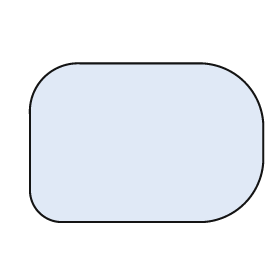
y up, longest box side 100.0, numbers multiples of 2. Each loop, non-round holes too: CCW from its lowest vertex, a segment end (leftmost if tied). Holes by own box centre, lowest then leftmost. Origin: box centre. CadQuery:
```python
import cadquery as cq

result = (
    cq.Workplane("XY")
    .moveTo(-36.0, -34.0)
    .lineTo(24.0, -34.0)
    .threePointArc((42.0, -26.0), (50.0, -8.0))
    .lineTo(50.0, 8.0)
    .threePointArc((42.0, 26.0), (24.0, 34.0))
    .lineTo(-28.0, 34.0)
    .threePointArc((-44.0, 28.0), (-50.0, 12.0))
    .lineTo(-50.0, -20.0)
    .threePointArc((-46.0, -30.0), (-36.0, -34.0))
    .close()
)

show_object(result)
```